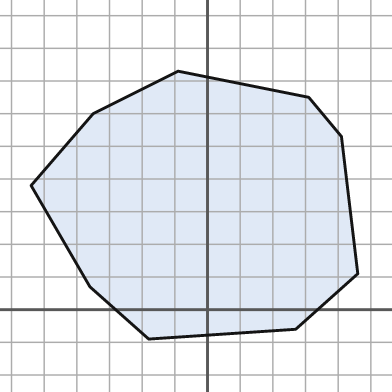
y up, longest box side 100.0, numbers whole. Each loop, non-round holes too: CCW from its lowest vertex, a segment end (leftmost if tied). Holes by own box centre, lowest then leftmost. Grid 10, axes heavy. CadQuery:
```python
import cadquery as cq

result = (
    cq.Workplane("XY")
    .moveTo(-18.0, -9.0)
    .lineTo(27.0, -6.0)
    .lineTo(46.0, 11.0)
    .lineTo(41.0, 53.0)
    .lineTo(31.0, 65.0)
    .lineTo(-9.0, 73.0)
    .lineTo(-35.0, 60.0)
    .lineTo(-54.0, 38.0)
    .lineTo(-36.0, 7.0)
    .close()
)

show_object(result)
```